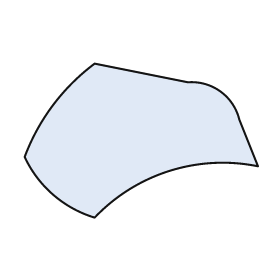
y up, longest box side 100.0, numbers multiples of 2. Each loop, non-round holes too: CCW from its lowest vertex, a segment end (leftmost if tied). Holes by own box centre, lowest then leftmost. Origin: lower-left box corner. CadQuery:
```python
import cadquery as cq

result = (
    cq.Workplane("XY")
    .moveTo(30.0, 0.0)
    .threePointArc((62.0, 20.0), (100.0, 22.0))
    .lineTo(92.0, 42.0)
    .threePointArc((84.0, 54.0), (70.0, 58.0))
    .lineTo(30.0, 66.0)
    .threePointArc((12.0, 48.0), (0.0, 26.0))
    .threePointArc((12.0, 10.0), (30.0, 0.0))
    .close()
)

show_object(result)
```